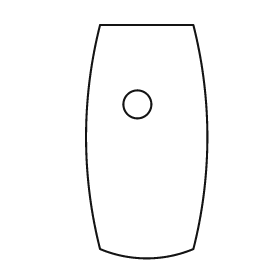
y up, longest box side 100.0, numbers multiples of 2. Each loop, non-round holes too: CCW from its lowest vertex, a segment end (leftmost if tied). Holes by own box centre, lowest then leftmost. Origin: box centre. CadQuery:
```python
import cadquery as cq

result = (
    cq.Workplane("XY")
    .moveTo(-20.0, -46.0)
    .threePointArc((0.0, -50.0), (20.0, -46.0))
    .threePointArc((26.0, 2.0), (20.0, 50.0))
    .lineTo(-20.0, 50.0)
    .threePointArc((-26.0, 2.0), (-20.0, -46.0))
    .close()
    .moveTo(-4.0, 16.0)
    .circle(6.0)
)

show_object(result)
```